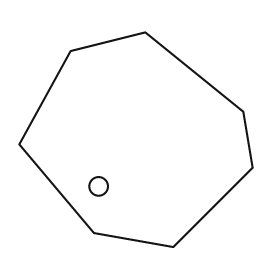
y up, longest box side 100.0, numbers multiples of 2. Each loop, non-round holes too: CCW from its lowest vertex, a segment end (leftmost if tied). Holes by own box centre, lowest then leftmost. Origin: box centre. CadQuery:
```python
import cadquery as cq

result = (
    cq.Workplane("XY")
    .moveTo(16.0, -46.0)
    .lineTo(50.0, -12.0)
    .lineTo(46.0, 12.0)
    .lineTo(4.0, 46.0)
    .lineTo(-28.0, 38.0)
    .lineTo(-50.0, -2.0)
    .lineTo(-18.0, -40.0)
    .close()
    .moveTo(-16.0, -20.0)
    .circle(4.0)
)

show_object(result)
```